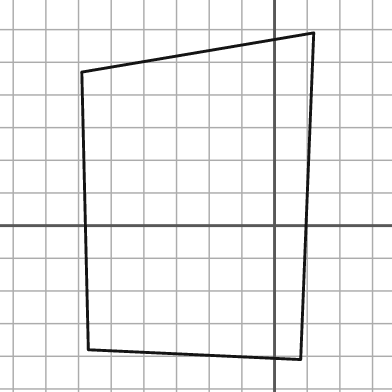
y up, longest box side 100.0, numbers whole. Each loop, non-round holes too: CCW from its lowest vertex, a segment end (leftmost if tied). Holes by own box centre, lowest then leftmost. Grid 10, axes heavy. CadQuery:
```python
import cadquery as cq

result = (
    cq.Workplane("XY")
    .moveTo(8.0, -41.0)
    .lineTo(12.0, 59.0)
    .lineTo(-59.0, 47.0)
    .lineTo(-57.0, -38.0)
    .close()
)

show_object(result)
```